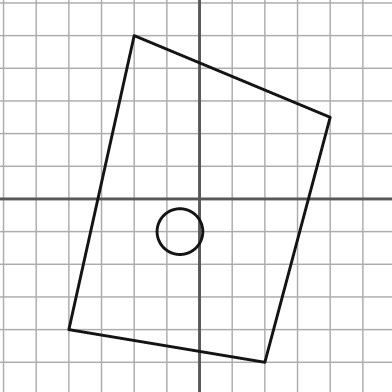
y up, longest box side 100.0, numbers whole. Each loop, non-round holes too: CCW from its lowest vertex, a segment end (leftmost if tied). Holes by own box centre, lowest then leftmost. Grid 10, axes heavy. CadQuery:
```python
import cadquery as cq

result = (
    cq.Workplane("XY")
    .moveTo(20.0, -50.0)
    .lineTo(40.0, 25.0)
    .lineTo(-20.0, 50.0)
    .lineTo(-40.0, -40.0)
    .close()
    .moveTo(-6.0, -10.0)
    .circle(7.0)
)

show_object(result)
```